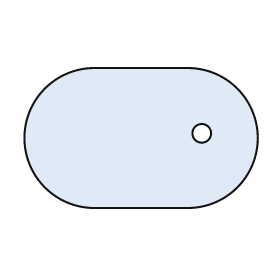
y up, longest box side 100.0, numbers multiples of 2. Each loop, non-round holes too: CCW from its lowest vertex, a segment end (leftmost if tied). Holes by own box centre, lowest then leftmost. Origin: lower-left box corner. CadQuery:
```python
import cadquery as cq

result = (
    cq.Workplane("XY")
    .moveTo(30.0, 0.0)
    .lineTo(70.0, 0.0)
    .threePointArc((100.0, 30.0), (70.0, 60.0))
    .lineTo(30.0, 60.0)
    .threePointArc((0.0, 30.0), (30.0, 0.0))
    .close()
    .moveTo(76.0, 32.0)
    .circle(4.0)
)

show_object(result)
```